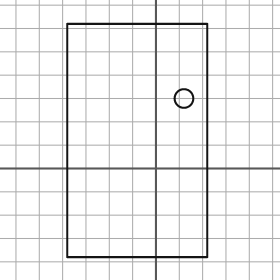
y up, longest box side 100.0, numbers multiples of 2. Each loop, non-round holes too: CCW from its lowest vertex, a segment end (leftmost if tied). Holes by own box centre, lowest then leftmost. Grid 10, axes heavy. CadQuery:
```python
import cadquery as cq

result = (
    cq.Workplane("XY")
    .moveTo(-38.0, -38.0)
    .lineTo(22.0, -38.0)
    .lineTo(22.0, 62.0)
    .lineTo(-38.0, 62.0)
    .close()
    .moveTo(12.0, 30.0)
    .circle(4.0)
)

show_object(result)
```